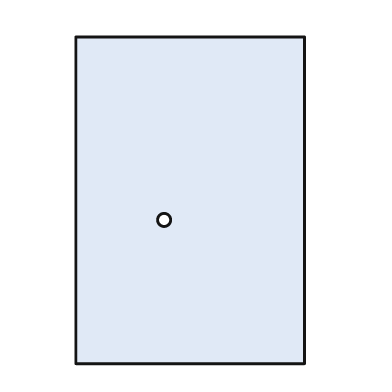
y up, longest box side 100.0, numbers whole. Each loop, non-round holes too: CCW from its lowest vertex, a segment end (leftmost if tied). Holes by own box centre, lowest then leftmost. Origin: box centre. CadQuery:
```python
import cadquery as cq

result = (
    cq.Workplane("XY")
    .moveTo(-35.0, -50.0)
    .lineTo(35.0, -50.0)
    .lineTo(35.0, 50.0)
    .lineTo(-35.0, 50.0)
    .close()
    .moveTo(-8.0, -6.0)
    .circle(2.0)
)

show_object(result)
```